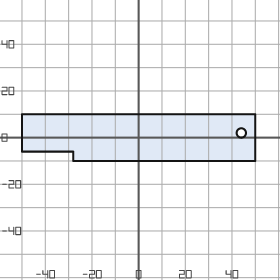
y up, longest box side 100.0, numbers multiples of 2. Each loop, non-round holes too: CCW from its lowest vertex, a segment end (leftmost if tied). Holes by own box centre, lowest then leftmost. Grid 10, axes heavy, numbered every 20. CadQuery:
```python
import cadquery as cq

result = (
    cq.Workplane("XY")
    .moveTo(-28.0, -10.0)
    .lineTo(50.0, -10.0)
    .lineTo(50.0, 10.0)
    .lineTo(-50.0, 10.0)
    .lineTo(-50.0, -6.0)
    .lineTo(-28.0, -6.0)
    .close()
    .moveTo(44.0, 2.0)
    .circle(2.0)
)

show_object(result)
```